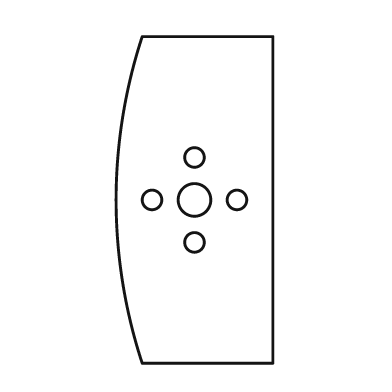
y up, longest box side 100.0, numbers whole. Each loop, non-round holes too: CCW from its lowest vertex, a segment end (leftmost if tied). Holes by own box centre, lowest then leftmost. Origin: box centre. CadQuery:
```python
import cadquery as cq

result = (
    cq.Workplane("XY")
    .moveTo(-16.0, -50.0)
    .lineTo(24.0, -50.0)
    .lineTo(24.0, 50.0)
    .lineTo(-16.0, 50.0)
    .threePointArc((-24.0, 0.0), (-16.0, -50.0))
    .close()
    .moveTo(0.0, -13.0)
    .circle(3.0)
    .moveTo(-13.0, 0.0)
    .circle(3.0)
    .moveTo(0.0, 0.0)
    .circle(5.0)
    .moveTo(13.0, 0.0)
    .circle(3.0)
    .moveTo(0.0, 13.0)
    .circle(3.0)
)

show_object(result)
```